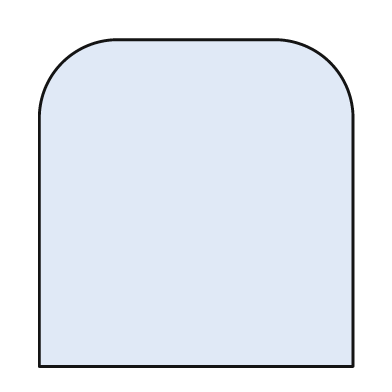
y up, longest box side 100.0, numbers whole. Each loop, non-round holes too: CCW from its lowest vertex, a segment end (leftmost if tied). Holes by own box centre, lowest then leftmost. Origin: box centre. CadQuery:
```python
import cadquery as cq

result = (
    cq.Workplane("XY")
    .moveTo(-48.0, -50.0)
    .lineTo(48.0, -50.0)
    .lineTo(48.0, 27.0)
    .threePointArc((41.0, 43.0), (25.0, 50.0))
    .lineTo(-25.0, 50.0)
    .threePointArc((-41.0, 43.0), (-48.0, 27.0))
    .close()
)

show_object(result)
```